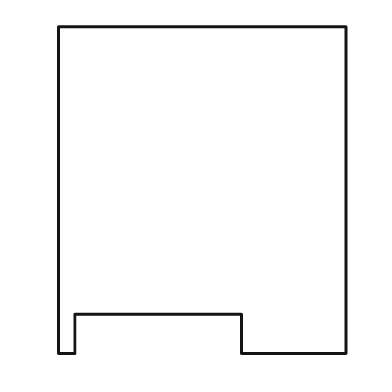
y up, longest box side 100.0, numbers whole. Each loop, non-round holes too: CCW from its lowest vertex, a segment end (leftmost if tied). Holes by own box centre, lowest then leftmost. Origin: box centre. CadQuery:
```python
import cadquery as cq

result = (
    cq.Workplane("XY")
    .moveTo(-44.0, -50.0)
    .lineTo(-39.0, -50.0)
    .lineTo(-39.0, -38.0)
    .lineTo(12.0, -38.0)
    .lineTo(12.0, -50.0)
    .lineTo(44.0, -50.0)
    .lineTo(44.0, 50.0)
    .lineTo(-44.0, 50.0)
    .close()
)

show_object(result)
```